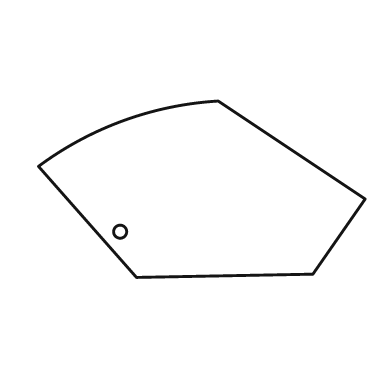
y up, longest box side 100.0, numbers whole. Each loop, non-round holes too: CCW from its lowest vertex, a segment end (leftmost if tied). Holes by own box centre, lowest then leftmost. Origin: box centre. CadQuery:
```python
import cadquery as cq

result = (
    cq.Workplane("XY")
    .moveTo(-20.0, -27.0)
    .lineTo(34.0, -26.0)
    .lineTo(50.0, -3.0)
    .lineTo(5.0, 27.0)
    .threePointArc((-24.0, 21.0), (-50.0, 7.0))
    .close()
    .moveTo(-25.0, -13.0)
    .circle(2.0)
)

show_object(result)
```